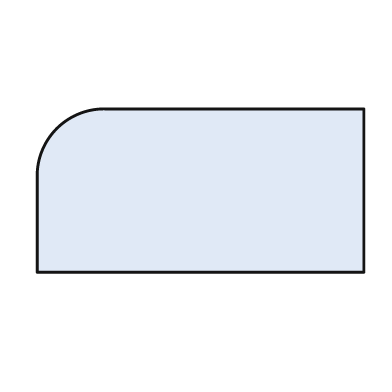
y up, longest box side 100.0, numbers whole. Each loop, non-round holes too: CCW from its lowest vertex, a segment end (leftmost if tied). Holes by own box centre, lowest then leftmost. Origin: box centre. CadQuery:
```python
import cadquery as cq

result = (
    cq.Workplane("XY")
    .moveTo(-50.0, -25.0)
    .lineTo(50.0, -25.0)
    .lineTo(50.0, 25.0)
    .lineTo(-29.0, 25.0)
    .threePointArc((-44.0, 19.0), (-50.0, 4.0))
    .close()
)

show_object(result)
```